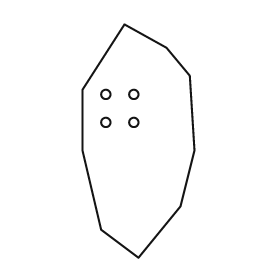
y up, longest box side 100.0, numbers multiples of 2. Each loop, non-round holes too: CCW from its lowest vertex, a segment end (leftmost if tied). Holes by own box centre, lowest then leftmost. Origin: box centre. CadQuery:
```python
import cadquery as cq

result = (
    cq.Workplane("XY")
    .moveTo(0.0, -50.0)
    .lineTo(18.0, -28.0)
    .lineTo(24.0, -4.0)
    .lineTo(22.0, 28.0)
    .lineTo(12.0, 40.0)
    .lineTo(-6.0, 50.0)
    .lineTo(-24.0, 22.0)
    .lineTo(-24.0, -4.0)
    .lineTo(-16.0, -38.0)
    .close()
    .moveTo(-14.0, 8.0)
    .circle(2.0)
    .moveTo(-2.0, 8.0)
    .circle(2.0)
    .moveTo(-14.0, 20.0)
    .circle(2.0)
    .moveTo(-2.0, 20.0)
    .circle(2.0)
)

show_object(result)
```